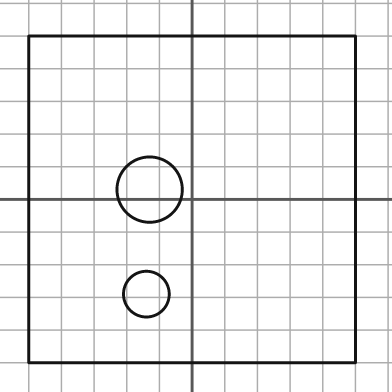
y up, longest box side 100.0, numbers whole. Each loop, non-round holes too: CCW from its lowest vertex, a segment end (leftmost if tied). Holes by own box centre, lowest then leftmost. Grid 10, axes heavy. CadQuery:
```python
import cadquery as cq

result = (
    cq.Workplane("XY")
    .moveTo(-50.0, -50.0)
    .lineTo(50.0, -50.0)
    .lineTo(50.0, 50.0)
    .lineTo(-50.0, 50.0)
    .close()
    .moveTo(-14.0, -29.0)
    .circle(7.0)
    .moveTo(-13.0, 3.0)
    .circle(10.0)
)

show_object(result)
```